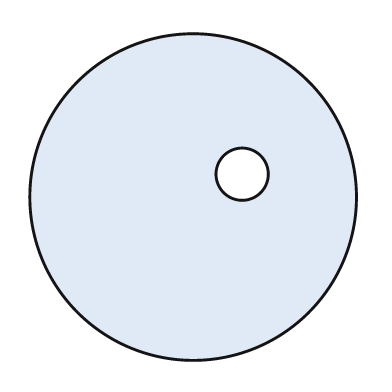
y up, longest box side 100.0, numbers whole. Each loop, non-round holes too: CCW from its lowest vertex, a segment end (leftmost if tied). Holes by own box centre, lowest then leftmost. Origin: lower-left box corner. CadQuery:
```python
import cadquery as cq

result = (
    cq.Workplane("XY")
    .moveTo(50.0, 50.0)
    .circle(50.0)
    .moveTo(65.0, 57.0)
    .circle(8.0)
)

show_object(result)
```